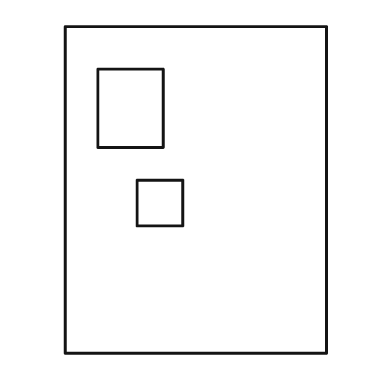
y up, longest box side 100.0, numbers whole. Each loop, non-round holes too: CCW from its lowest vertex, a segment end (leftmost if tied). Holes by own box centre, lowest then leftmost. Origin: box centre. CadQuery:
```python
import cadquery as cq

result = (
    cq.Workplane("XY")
    .moveTo(-40.0, -50.0)
    .lineTo(40.0, -50.0)
    .lineTo(40.0, 50.0)
    .lineTo(-40.0, 50.0)
    .close()
    .moveTo(-18.0, -11.0)
    .lineTo(-4.0, -11.0)
    .lineTo(-4.0, 3.0)
    .lineTo(-18.0, 3.0)
    .close()
    .moveTo(-30.0, 13.0)
    .lineTo(-10.0, 13.0)
    .lineTo(-10.0, 37.0)
    .lineTo(-30.0, 37.0)
    .close()
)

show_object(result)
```